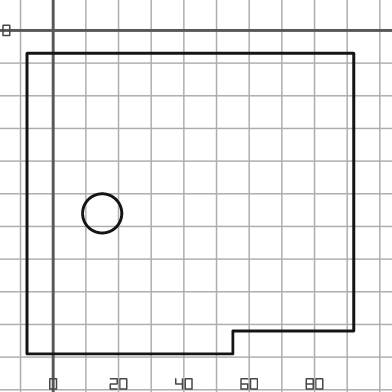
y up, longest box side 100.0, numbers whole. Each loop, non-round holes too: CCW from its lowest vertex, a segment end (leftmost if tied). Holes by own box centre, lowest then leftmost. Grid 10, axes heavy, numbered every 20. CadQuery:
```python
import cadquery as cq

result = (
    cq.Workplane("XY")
    .moveTo(-8.0, -99.0)
    .lineTo(55.0, -99.0)
    .lineTo(55.0, -92.0)
    .lineTo(92.0, -92.0)
    .lineTo(92.0, -7.0)
    .lineTo(-8.0, -7.0)
    .close()
    .moveTo(15.0, -56.0)
    .circle(6.0)
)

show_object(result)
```